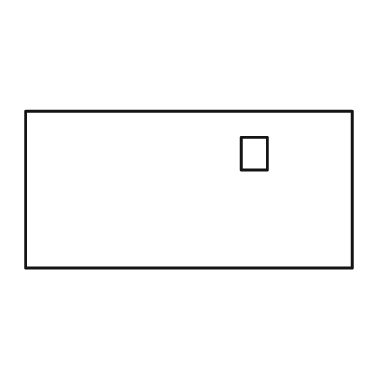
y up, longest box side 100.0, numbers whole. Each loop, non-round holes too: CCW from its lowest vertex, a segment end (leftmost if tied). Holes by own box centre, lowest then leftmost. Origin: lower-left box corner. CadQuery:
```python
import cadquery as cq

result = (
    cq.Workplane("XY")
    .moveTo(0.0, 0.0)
    .lineTo(100.0, 0.0)
    .lineTo(100.0, 48.0)
    .lineTo(0.0, 48.0)
    .close()
    .moveTo(66.0, 30.0)
    .lineTo(74.0, 30.0)
    .lineTo(74.0, 40.0)
    .lineTo(66.0, 40.0)
    .close()
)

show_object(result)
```